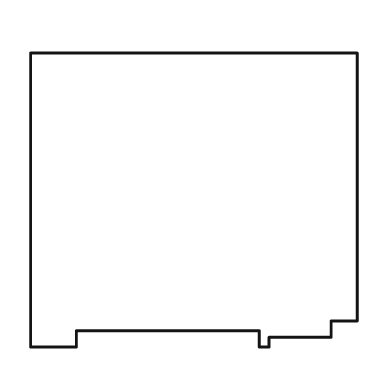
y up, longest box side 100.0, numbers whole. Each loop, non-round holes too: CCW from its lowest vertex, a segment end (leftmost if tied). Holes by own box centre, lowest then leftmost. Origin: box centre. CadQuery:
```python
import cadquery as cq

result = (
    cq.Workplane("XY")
    .moveTo(-50.0, -45.0)
    .lineTo(-36.0, -45.0)
    .lineTo(-36.0, -40.0)
    .lineTo(20.0, -40.0)
    .lineTo(20.0, -45.0)
    .lineTo(23.0, -45.0)
    .lineTo(23.0, -42.0)
    .lineTo(42.0, -42.0)
    .lineTo(42.0, -37.0)
    .lineTo(50.0, -37.0)
    .lineTo(50.0, 45.0)
    .lineTo(-50.0, 45.0)
    .close()
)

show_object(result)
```